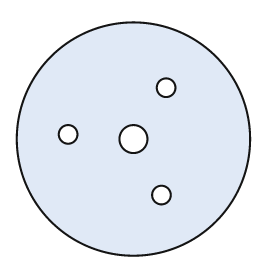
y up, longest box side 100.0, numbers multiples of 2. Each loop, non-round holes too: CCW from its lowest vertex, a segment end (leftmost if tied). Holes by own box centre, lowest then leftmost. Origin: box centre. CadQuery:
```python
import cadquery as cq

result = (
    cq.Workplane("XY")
    .moveTo(0.0, 0.0)
    .circle(50.0)
    .moveTo(12.0, -24.0)
    .circle(4.0)
    .moveTo(0.0, 0.0)
    .circle(6.0)
    .moveTo(-28.0, 2.0)
    .circle(4.0)
    .moveTo(14.0, 22.0)
    .circle(4.0)
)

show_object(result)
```